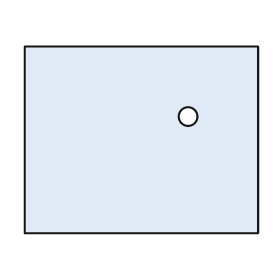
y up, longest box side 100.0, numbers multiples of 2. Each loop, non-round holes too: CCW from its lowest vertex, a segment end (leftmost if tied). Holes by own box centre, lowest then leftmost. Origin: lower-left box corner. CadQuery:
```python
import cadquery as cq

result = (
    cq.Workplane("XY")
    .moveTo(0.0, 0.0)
    .lineTo(100.0, 0.0)
    .lineTo(100.0, 80.0)
    .lineTo(0.0, 80.0)
    .close()
    .moveTo(70.0, 50.0)
    .circle(4.0)
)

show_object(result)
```